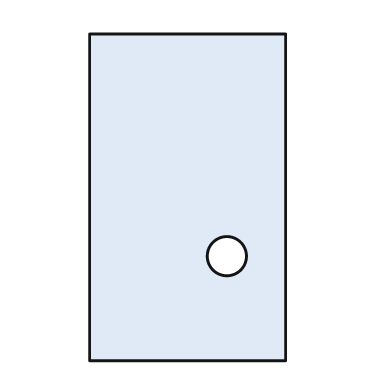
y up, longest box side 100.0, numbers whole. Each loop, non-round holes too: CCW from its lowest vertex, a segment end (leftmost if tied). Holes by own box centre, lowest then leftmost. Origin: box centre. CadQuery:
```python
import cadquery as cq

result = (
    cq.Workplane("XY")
    .moveTo(-30.0, -50.0)
    .lineTo(30.0, -50.0)
    .lineTo(30.0, 50.0)
    .lineTo(-30.0, 50.0)
    .close()
    .moveTo(12.0, -18.0)
    .circle(6.0)
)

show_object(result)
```